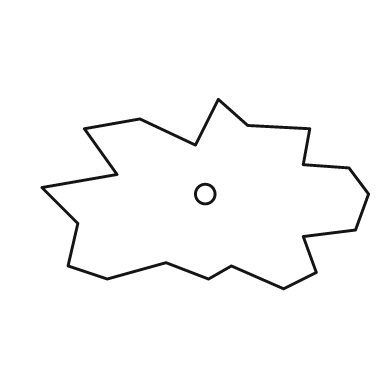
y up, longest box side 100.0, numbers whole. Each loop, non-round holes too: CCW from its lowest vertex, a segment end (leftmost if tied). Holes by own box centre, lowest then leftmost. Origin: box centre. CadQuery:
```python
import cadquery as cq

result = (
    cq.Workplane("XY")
    .moveTo(24.0, -29.0)
    .lineTo(34.0, -24.0)
    .lineTo(30.0, -13.0)
    .lineTo(46.0, -11.0)
    .lineTo(50.0, 0.0)
    .lineTo(44.0, 8.0)
    .lineTo(30.0, 9.0)
    .lineTo(32.0, 20.0)
    .lineTo(13.0, 21.0)
    .lineTo(4.0, 29.0)
    .lineTo(-3.0, 15.0)
    .lineTo(-20.0, 23.0)
    .lineTo(-37.0, 20.0)
    .lineTo(-27.0, 6.0)
    .lineTo(-50.0, 2.0)
    .lineTo(-39.0, -9.0)
    .lineTo(-42.0, -22.0)
    .lineTo(-30.0, -26.0)
    .lineTo(-12.0, -21.0)
    .lineTo(1.0, -26.0)
    .lineTo(8.0, -22.0)
    .close()
    .moveTo(0.0, 0.0)
    .circle(3.0)
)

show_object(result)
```